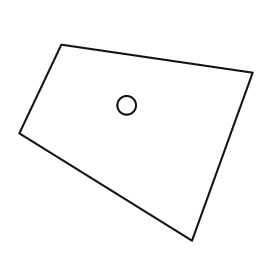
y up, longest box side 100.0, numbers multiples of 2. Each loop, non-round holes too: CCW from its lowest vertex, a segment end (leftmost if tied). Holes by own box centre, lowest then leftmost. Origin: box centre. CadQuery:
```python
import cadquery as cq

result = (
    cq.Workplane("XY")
    .moveTo(24.0, -42.0)
    .lineTo(50.0, 30.0)
    .lineTo(-32.0, 42.0)
    .lineTo(-50.0, 4.0)
    .close()
    .moveTo(-4.0, 16.0)
    .circle(4.0)
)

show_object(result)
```